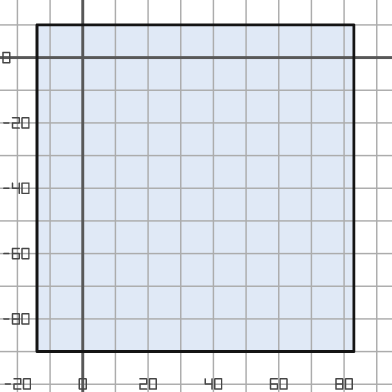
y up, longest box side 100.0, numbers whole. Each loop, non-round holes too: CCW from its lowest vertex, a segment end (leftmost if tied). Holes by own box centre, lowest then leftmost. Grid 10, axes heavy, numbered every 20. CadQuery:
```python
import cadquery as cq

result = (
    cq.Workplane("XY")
    .moveTo(-14.0, -90.0)
    .lineTo(83.0, -90.0)
    .lineTo(83.0, 10.0)
    .lineTo(-14.0, 10.0)
    .close()
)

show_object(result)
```